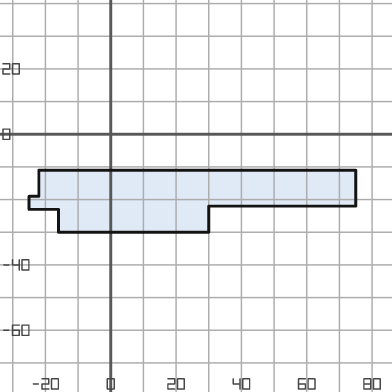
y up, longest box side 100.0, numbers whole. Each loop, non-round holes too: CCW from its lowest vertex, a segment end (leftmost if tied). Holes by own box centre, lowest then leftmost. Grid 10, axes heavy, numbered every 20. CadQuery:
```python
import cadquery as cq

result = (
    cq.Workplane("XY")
    .moveTo(-16.0, -30.0)
    .lineTo(30.0, -30.0)
    .lineTo(30.0, -22.0)
    .lineTo(75.0, -22.0)
    .lineTo(75.0, -11.0)
    .lineTo(-22.0, -11.0)
    .lineTo(-22.0, -19.0)
    .lineTo(-25.0, -19.0)
    .lineTo(-25.0, -23.0)
    .lineTo(-16.0, -23.0)
    .close()
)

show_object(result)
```